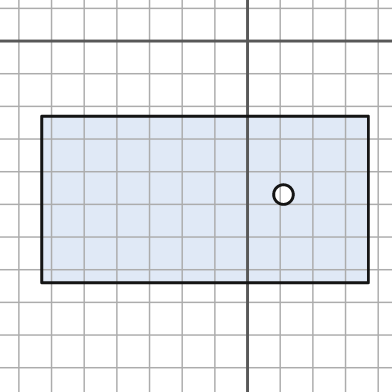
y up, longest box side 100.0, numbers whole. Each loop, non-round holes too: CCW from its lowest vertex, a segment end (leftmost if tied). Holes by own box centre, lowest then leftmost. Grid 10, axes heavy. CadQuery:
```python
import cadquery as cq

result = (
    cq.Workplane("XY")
    .moveTo(-63.0, -74.0)
    .lineTo(37.0, -74.0)
    .lineTo(37.0, -23.0)
    .lineTo(-63.0, -23.0)
    .close()
    .moveTo(11.0, -47.0)
    .circle(3.0)
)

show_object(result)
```